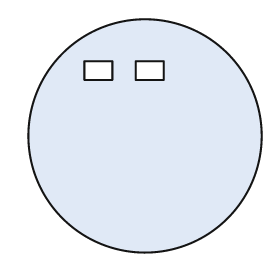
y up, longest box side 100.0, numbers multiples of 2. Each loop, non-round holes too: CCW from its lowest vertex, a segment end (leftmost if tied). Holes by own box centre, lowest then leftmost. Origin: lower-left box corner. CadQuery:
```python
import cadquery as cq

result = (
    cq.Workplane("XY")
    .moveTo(50.0, 50.0)
    .circle(50.0)
    .moveTo(24.0, 74.0)
    .lineTo(36.0, 74.0)
    .lineTo(36.0, 82.0)
    .lineTo(24.0, 82.0)
    .close()
    .moveTo(46.0, 74.0)
    .lineTo(58.0, 74.0)
    .lineTo(58.0, 82.0)
    .lineTo(46.0, 82.0)
    .close()
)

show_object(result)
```